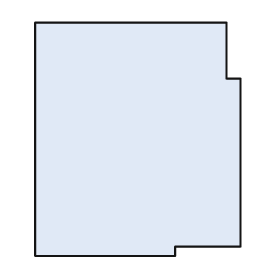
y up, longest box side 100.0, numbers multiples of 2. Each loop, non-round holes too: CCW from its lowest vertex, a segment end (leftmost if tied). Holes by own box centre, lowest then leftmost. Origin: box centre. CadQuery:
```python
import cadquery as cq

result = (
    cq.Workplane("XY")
    .moveTo(-44.0, -50.0)
    .lineTo(16.0, -50.0)
    .lineTo(16.0, -46.0)
    .lineTo(44.0, -46.0)
    .lineTo(44.0, 26.0)
    .lineTo(38.0, 26.0)
    .lineTo(38.0, 50.0)
    .lineTo(-44.0, 50.0)
    .close()
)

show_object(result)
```